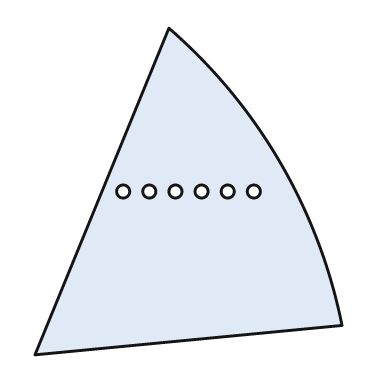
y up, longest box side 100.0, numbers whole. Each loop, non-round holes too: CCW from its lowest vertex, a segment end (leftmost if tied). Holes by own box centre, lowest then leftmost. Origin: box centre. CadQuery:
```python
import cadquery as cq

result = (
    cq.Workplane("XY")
    .moveTo(-47.0, -50.0)
    .lineTo(47.0, -41.0)
    .threePointArc((28.0, 9.0), (-6.0, 50.0))
    .close()
    .moveTo(-20.0, 0.0)
    .circle(2.0)
    .moveTo(-12.0, 0.0)
    .circle(2.0)
    .moveTo(-4.0, 0.0)
    .circle(2.0)
    .moveTo(4.0, 0.0)
    .circle(2.0)
    .moveTo(12.0, 0.0)
    .circle(2.0)
    .moveTo(20.0, 0.0)
    .circle(2.0)
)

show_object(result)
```